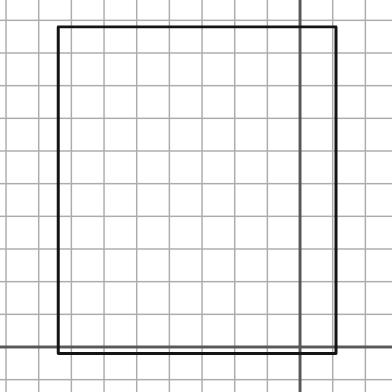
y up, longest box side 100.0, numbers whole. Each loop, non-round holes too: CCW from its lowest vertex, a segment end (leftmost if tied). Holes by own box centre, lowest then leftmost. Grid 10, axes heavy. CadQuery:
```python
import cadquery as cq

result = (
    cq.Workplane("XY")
    .moveTo(-74.0, -2.0)
    .lineTo(11.0, -2.0)
    .lineTo(11.0, 98.0)
    .lineTo(-74.0, 98.0)
    .close()
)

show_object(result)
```